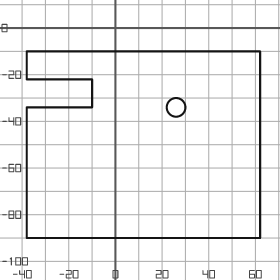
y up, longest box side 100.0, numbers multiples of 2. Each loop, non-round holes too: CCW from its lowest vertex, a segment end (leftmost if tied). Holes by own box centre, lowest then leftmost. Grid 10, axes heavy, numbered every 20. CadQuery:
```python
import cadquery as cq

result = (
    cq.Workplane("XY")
    .moveTo(-38.0, -90.0)
    .lineTo(62.0, -90.0)
    .lineTo(62.0, -10.0)
    .lineTo(-38.0, -10.0)
    .lineTo(-38.0, -22.0)
    .lineTo(-10.0, -22.0)
    .lineTo(-10.0, -34.0)
    .lineTo(-38.0, -34.0)
    .close()
    .moveTo(26.0, -34.0)
    .circle(4.0)
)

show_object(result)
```